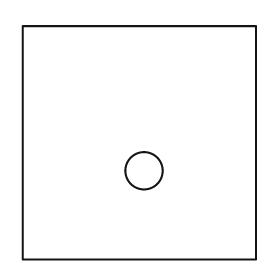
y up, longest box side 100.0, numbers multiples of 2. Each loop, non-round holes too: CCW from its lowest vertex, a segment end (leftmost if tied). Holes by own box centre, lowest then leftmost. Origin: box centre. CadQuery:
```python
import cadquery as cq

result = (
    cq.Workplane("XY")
    .moveTo(-50.0, -50.0)
    .lineTo(50.0, -50.0)
    .lineTo(50.0, 50.0)
    .lineTo(-50.0, 50.0)
    .close()
    .moveTo(2.0, -12.0)
    .circle(8.0)
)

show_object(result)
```